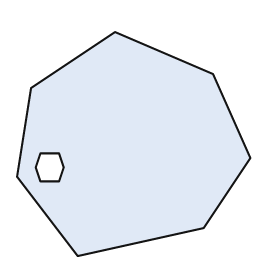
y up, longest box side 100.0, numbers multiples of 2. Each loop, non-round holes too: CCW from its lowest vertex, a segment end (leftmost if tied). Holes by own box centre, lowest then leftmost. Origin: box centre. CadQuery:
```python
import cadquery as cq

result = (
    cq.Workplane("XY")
    .moveTo(-24.0, -48.0)
    .lineTo(30.0, -36.0)
    .lineTo(50.0, -6.0)
    .lineTo(34.0, 30.0)
    .lineTo(-8.0, 48.0)
    .lineTo(-44.0, 24.0)
    .lineTo(-50.0, -14.0)
    .close()
    .moveTo(-40.0, -16.0)
    .lineTo(-32.0, -16.0)
    .lineTo(-30.0, -10.0)
    .lineTo(-32.0, -4.0)
    .lineTo(-40.0, -4.0)
    .lineTo(-42.0, -10.0)
    .close()
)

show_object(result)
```